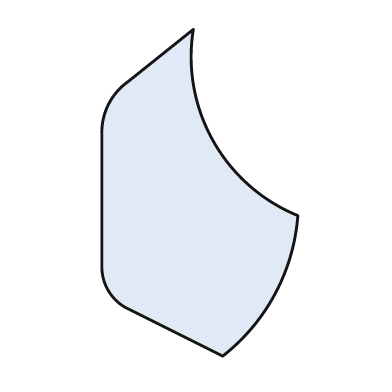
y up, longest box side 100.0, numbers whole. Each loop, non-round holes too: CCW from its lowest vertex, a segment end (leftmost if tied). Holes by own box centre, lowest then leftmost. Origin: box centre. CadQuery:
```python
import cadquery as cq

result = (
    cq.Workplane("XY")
    .moveTo(7.0, -50.0)
    .threePointArc((23.0, -31.0), (30.0, -7.0))
    .threePointArc((4.0, 16.0), (-2.0, 50.0))
    .lineTo(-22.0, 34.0)
    .threePointArc((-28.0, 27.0), (-30.0, 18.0))
    .lineTo(-30.0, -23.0)
    .threePointArc((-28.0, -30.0), (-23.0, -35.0))
    .close()
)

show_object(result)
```